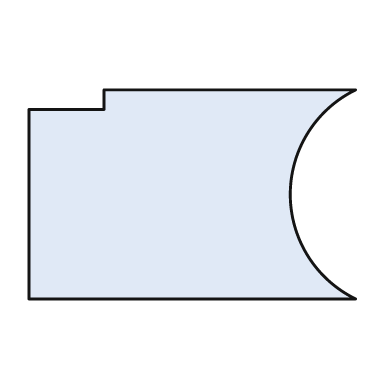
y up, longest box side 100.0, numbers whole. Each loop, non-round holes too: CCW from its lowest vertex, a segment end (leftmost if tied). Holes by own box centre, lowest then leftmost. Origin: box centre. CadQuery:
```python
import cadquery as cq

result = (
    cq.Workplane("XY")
    .moveTo(-50.0, -32.0)
    .lineTo(50.0, -32.0)
    .threePointArc((30.0, 0.0), (50.0, 32.0))
    .lineTo(-27.0, 32.0)
    .lineTo(-27.0, 26.0)
    .lineTo(-50.0, 26.0)
    .close()
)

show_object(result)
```